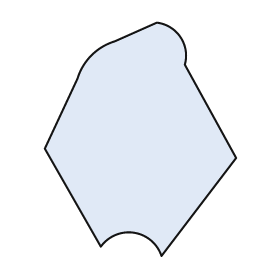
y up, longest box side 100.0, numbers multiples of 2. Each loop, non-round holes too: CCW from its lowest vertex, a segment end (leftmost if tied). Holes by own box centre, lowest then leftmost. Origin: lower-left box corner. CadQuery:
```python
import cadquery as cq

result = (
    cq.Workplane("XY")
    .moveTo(50.0, 0.0)
    .lineTo(82.0, 42.0)
    .lineTo(60.0, 82.0)
    .threePointArc((58.0, 94.0), (48.0, 100.0))
    .lineTo(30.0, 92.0)
    .threePointArc((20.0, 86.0), (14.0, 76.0))
    .lineTo(0.0, 46.0)
    .lineTo(24.0, 4.0)
    .threePointArc((38.0, 10.0), (50.0, 0.0))
    .close()
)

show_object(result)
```